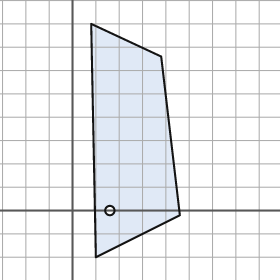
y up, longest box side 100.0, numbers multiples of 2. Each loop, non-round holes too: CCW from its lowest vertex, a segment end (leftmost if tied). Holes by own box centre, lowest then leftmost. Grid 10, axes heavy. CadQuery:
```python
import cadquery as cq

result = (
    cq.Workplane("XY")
    .moveTo(10.0, -20.0)
    .lineTo(46.0, -2.0)
    .lineTo(38.0, 66.0)
    .lineTo(8.0, 80.0)
    .close()
    .moveTo(16.0, 0.0)
    .circle(2.0)
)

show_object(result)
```